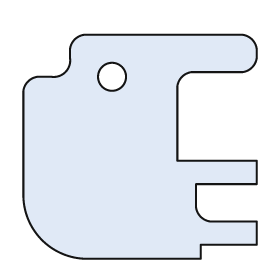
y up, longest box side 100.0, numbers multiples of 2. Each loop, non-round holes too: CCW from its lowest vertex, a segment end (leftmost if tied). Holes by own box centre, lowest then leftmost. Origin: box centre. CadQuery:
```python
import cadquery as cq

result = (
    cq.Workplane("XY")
    .moveTo(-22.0, -48.0)
    .lineTo(26.0, -48.0)
    .lineTo(26.0, -42.0)
    .lineTo(50.0, -42.0)
    .lineTo(50.0, -32.0)
    .lineTo(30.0, -32.0)
    .threePointArc((26.0, -30.0), (24.0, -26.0))
    .lineTo(24.0, -16.0)
    .lineTo(50.0, -16.0)
    .lineTo(50.0, -6.0)
    .lineTo(16.0, -6.0)
    .lineTo(16.0, 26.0)
    .threePointArc((18.0, 30.0), (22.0, 32.0))
    .lineTo(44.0, 32.0)
    .threePointArc((48.0, 34.0), (50.0, 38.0))
    .lineTo(50.0, 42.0)
    .threePointArc((48.0, 46.0), (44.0, 48.0))
    .lineTo(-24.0, 48.0)
    .threePointArc((-28.0, 46.0), (-30.0, 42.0))
    .lineTo(-30.0, 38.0)
    .threePointArc((-32.0, 32.0), (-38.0, 30.0))
    .lineTo(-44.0, 30.0)
    .threePointArc((-48.0, 28.0), (-50.0, 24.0))
    .lineTo(-50.0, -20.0)
    .threePointArc((-42.0, -40.0), (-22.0, -48.0))
    .close()
    .moveTo(-12.0, 30.0)
    .circle(6.0)
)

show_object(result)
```